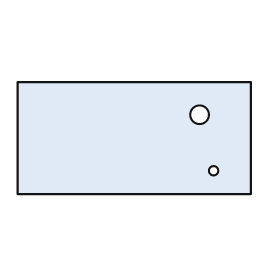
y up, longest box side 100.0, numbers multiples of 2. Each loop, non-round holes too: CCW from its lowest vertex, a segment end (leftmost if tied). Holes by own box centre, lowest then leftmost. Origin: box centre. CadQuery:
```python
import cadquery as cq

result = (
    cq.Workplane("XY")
    .moveTo(-50.0, -24.0)
    .lineTo(50.0, -24.0)
    .lineTo(50.0, 24.0)
    .lineTo(-50.0, 24.0)
    .close()
    .moveTo(34.0, -14.0)
    .circle(2.0)
    .moveTo(28.0, 10.0)
    .circle(4.0)
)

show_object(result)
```